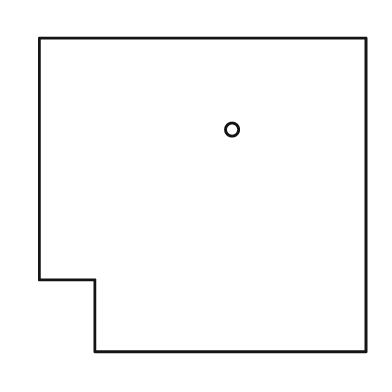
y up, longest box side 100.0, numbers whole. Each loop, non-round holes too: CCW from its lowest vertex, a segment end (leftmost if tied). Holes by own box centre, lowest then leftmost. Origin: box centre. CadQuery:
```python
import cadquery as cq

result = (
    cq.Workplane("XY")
    .moveTo(-33.0, -48.0)
    .lineTo(50.0, -48.0)
    .lineTo(50.0, 48.0)
    .lineTo(-50.0, 48.0)
    .lineTo(-50.0, -26.0)
    .lineTo(-33.0, -26.0)
    .close()
    .moveTo(9.0, 20.0)
    .circle(2.0)
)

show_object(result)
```